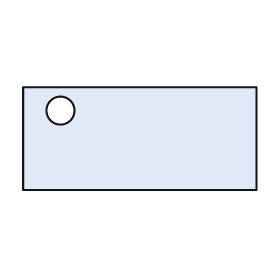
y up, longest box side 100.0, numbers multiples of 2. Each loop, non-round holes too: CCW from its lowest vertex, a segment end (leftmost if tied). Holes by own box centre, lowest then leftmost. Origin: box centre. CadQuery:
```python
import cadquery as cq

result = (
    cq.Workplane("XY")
    .moveTo(-50.0, -22.0)
    .lineTo(50.0, -22.0)
    .lineTo(50.0, 22.0)
    .lineTo(-50.0, 22.0)
    .close()
    .moveTo(-34.0, 12.0)
    .circle(6.0)
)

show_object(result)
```